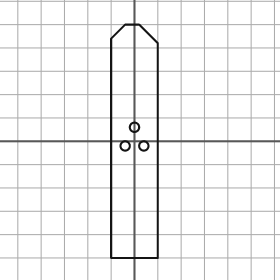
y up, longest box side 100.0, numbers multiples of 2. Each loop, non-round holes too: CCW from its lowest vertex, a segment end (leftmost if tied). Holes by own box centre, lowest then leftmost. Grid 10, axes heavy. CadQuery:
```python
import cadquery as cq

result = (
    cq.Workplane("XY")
    .moveTo(-10.0, -50.0)
    .lineTo(10.0, -50.0)
    .lineTo(10.0, 42.0)
    .lineTo(2.0, 50.0)
    .lineTo(-4.0, 50.0)
    .lineTo(-10.0, 44.0)
    .close()
    .moveTo(-4.0, -2.0)
    .circle(2.0)
    .moveTo(4.0, -2.0)
    .circle(2.0)
    .moveTo(0.0, 6.0)
    .circle(2.0)
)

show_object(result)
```